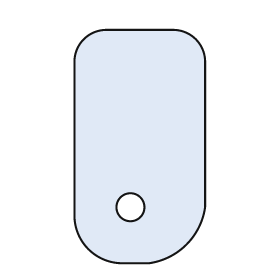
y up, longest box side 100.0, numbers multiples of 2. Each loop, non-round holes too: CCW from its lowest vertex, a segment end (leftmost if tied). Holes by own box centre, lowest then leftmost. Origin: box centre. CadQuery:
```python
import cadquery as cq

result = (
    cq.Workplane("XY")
    .moveTo(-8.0, -50.0)
    .lineTo(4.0, -50.0)
    .threePointArc((20.0, -42.0), (28.0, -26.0))
    .lineTo(28.0, 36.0)
    .threePointArc((24.0, 46.0), (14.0, 50.0))
    .lineTo(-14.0, 50.0)
    .threePointArc((-24.0, 46.0), (-28.0, 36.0))
    .lineTo(-28.0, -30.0)
    .threePointArc((-22.0, -44.0), (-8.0, -50.0))
    .close()
    .moveTo(-4.0, -26.0)
    .circle(6.0)
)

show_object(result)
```